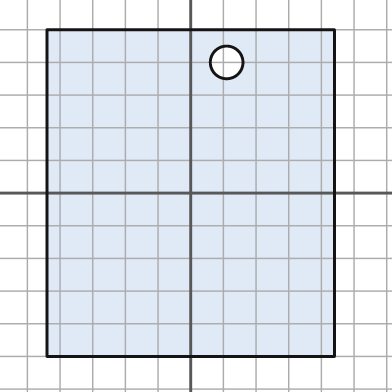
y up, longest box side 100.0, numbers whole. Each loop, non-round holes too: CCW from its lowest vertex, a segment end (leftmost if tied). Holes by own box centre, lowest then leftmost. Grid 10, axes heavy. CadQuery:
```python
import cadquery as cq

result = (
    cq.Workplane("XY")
    .moveTo(-44.0, -50.0)
    .lineTo(44.0, -50.0)
    .lineTo(44.0, 50.0)
    .lineTo(-44.0, 50.0)
    .close()
    .moveTo(11.0, 40.0)
    .circle(5.0)
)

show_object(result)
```